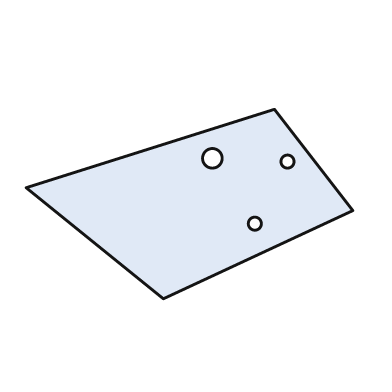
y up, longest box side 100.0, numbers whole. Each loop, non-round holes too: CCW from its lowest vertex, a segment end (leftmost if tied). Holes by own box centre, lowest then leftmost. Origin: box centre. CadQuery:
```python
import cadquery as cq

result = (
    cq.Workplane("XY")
    .moveTo(-8.0, -29.0)
    .lineTo(50.0, -2.0)
    .lineTo(26.0, 29.0)
    .lineTo(-50.0, 5.0)
    .close()
    .moveTo(20.0, -6.0)
    .circle(2.0)
    .moveTo(30.0, 13.0)
    .circle(2.0)
    .moveTo(7.0, 14.0)
    .circle(3.0)
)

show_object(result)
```